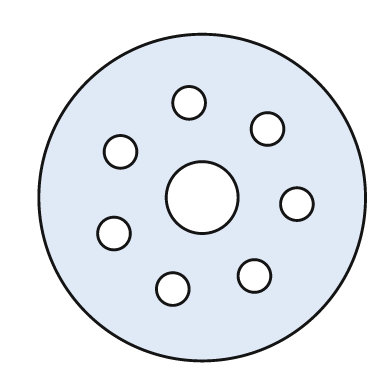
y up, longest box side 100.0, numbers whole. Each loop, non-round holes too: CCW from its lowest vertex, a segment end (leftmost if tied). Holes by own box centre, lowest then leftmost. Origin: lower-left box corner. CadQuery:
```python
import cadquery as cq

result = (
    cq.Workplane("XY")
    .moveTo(50.0, 50.0)
    .circle(50.0)
    .moveTo(41.0, 22.0)
    .circle(5.0)
    .moveTo(66.0, 26.0)
    .circle(5.0)
    .moveTo(23.0, 39.0)
    .circle(5.0)
    .moveTo(79.0, 48.0)
    .circle(5.0)
    .moveTo(50.0, 50.0)
    .circle(11.0)
    .moveTo(25.0, 64.0)
    .circle(5.0)
    .moveTo(70.0, 71.0)
    .circle(5.0)
    .moveTo(46.0, 79.0)
    .circle(5.0)
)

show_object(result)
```